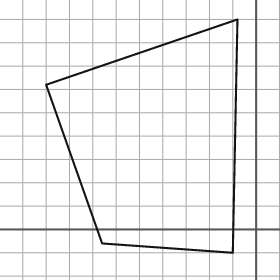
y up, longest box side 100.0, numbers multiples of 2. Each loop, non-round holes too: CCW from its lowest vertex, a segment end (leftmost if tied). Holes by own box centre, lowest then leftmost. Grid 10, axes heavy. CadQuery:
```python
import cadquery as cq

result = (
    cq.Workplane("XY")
    .moveTo(-10.0, -10.0)
    .lineTo(-8.0, 90.0)
    .lineTo(-90.0, 62.0)
    .lineTo(-66.0, -6.0)
    .close()
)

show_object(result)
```